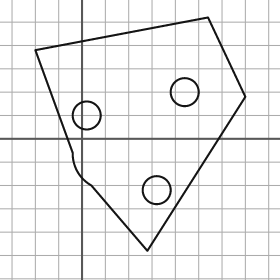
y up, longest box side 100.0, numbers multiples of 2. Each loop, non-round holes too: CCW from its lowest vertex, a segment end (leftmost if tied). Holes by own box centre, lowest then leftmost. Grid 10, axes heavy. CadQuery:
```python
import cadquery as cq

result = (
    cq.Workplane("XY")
    .moveTo(28.0, -48.0)
    .lineTo(70.0, 18.0)
    .lineTo(54.0, 52.0)
    .lineTo(-20.0, 38.0)
    .lineTo(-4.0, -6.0)
    .threePointArc((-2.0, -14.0), (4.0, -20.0))
    .close()
    .moveTo(32.0, -22.0)
    .circle(6.0)
    .moveTo(2.0, 10.0)
    .circle(6.0)
    .moveTo(44.0, 20.0)
    .circle(6.0)
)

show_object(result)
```